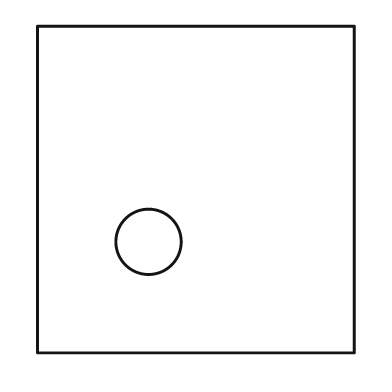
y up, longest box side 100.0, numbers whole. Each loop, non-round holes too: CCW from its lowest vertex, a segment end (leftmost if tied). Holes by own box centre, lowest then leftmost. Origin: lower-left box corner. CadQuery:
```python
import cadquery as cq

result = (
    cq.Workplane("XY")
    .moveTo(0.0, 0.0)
    .lineTo(97.0, 0.0)
    .lineTo(97.0, 100.0)
    .lineTo(0.0, 100.0)
    .close()
    .moveTo(34.0, 34.0)
    .circle(10.0)
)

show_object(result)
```